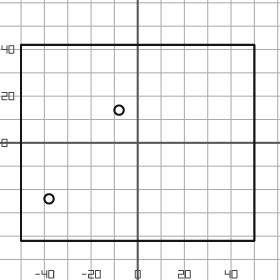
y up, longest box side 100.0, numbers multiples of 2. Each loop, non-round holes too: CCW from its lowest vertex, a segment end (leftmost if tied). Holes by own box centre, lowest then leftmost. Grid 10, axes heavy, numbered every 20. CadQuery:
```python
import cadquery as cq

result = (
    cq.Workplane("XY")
    .moveTo(-50.0, -42.0)
    .lineTo(50.0, -42.0)
    .lineTo(50.0, 42.0)
    .lineTo(-50.0, 42.0)
    .close()
    .moveTo(-38.0, -24.0)
    .circle(2.0)
    .moveTo(-8.0, 14.0)
    .circle(2.0)
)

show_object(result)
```